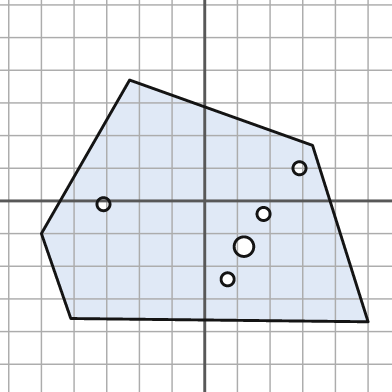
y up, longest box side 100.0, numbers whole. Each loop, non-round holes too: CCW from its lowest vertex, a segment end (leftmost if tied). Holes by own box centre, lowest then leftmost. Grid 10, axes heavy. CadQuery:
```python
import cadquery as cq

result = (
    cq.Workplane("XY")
    .moveTo(50.0, -37.0)
    .lineTo(33.0, 17.0)
    .lineTo(-23.0, 37.0)
    .lineTo(-50.0, -10.0)
    .lineTo(-41.0, -36.0)
    .close()
    .moveTo(7.0, -24.0)
    .circle(2.0)
    .moveTo(12.0, -14.0)
    .circle(3.0)
    .moveTo(18.0, -4.0)
    .circle(2.0)
    .moveTo(-31.0, -1.0)
    .circle(2.0)
    .moveTo(29.0, 10.0)
    .circle(2.0)
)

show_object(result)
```